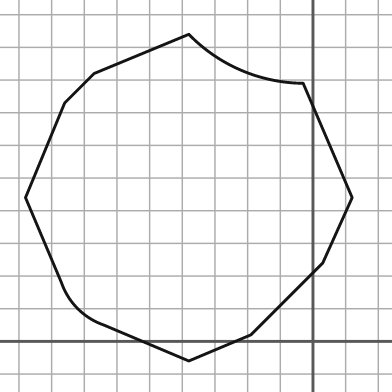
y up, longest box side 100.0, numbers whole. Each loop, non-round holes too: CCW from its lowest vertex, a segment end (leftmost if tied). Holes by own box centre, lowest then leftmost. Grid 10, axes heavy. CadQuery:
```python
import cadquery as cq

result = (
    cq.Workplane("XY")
    .moveTo(-38.0, -6.0)
    .lineTo(-19.0, 2.0)
    .lineTo(3.0, 24.0)
    .lineTo(12.0, 44.0)
    .lineTo(-3.0, 79.0)
    .threePointArc((-22.0, 83.0), (-38.0, 94.0))
    .lineTo(-67.0, 82.0)
    .lineTo(-76.0, 73.0)
    .lineTo(-88.0, 44.0)
    .lineTo(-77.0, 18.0)
    .threePointArc((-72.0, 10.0), (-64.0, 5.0))
    .close()
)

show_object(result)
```